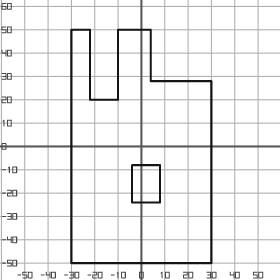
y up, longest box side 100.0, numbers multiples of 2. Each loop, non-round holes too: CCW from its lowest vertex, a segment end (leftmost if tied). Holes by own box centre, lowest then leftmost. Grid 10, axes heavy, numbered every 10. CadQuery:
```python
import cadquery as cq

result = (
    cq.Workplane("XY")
    .moveTo(-30.0, -50.0)
    .lineTo(30.0, -50.0)
    .lineTo(30.0, 28.0)
    .lineTo(4.0, 28.0)
    .lineTo(4.0, 50.0)
    .lineTo(-10.0, 50.0)
    .lineTo(-10.0, 20.0)
    .lineTo(-22.0, 20.0)
    .lineTo(-22.0, 50.0)
    .lineTo(-30.0, 50.0)
    .close()
    .moveTo(-4.0, -24.0)
    .lineTo(8.0, -24.0)
    .lineTo(8.0, -8.0)
    .lineTo(-4.0, -8.0)
    .close()
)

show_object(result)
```